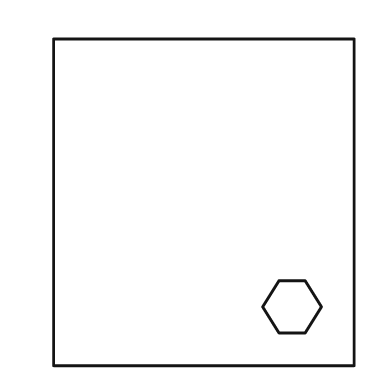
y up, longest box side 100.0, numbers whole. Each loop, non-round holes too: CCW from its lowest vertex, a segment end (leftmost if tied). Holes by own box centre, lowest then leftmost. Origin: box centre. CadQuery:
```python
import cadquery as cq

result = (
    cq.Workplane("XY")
    .moveTo(-46.0, -50.0)
    .lineTo(46.0, -50.0)
    .lineTo(46.0, 50.0)
    .lineTo(-46.0, 50.0)
    .close()
    .moveTo(23.0, -40.0)
    .lineTo(31.0, -40.0)
    .lineTo(36.0, -32.0)
    .lineTo(31.0, -24.0)
    .lineTo(23.0, -24.0)
    .lineTo(18.0, -32.0)
    .close()
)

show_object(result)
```